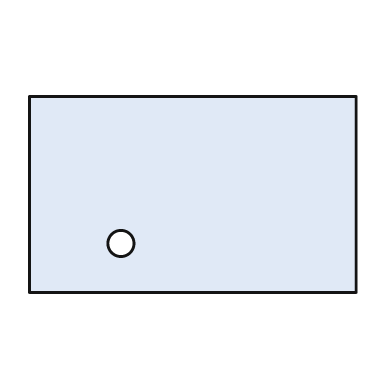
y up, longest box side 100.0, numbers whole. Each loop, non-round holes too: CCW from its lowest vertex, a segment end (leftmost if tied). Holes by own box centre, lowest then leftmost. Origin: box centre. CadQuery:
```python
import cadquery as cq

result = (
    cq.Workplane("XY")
    .moveTo(-50.0, -30.0)
    .lineTo(50.0, -30.0)
    .lineTo(50.0, 30.0)
    .lineTo(-50.0, 30.0)
    .close()
    .moveTo(-22.0, -15.0)
    .circle(4.0)
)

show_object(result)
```